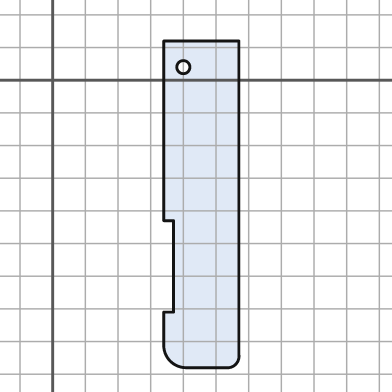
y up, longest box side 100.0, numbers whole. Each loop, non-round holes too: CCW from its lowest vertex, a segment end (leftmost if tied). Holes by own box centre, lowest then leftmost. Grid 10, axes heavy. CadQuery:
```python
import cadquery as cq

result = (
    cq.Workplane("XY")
    .moveTo(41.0, -88.0)
    .lineTo(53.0, -88.0)
    .threePointArc((56.0, -87.0), (57.0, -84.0))
    .lineTo(57.0, 12.0)
    .lineTo(34.0, 12.0)
    .lineTo(34.0, -43.0)
    .lineTo(37.0, -43.0)
    .lineTo(37.0, -71.0)
    .lineTo(34.0, -71.0)
    .lineTo(34.0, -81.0)
    .threePointArc((36.0, -86.0), (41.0, -88.0))
    .close()
    .moveTo(40.0, 4.0)
    .circle(2.0)
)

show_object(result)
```